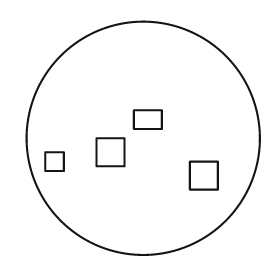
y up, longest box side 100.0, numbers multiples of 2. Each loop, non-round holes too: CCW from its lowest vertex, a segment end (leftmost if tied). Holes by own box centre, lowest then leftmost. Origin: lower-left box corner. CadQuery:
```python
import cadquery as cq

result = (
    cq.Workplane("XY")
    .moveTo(50.0, 50.0)
    .circle(50.0)
    .moveTo(70.0, 28.0)
    .lineTo(82.0, 28.0)
    .lineTo(82.0, 40.0)
    .lineTo(70.0, 40.0)
    .close()
    .moveTo(8.0, 36.0)
    .lineTo(16.0, 36.0)
    .lineTo(16.0, 44.0)
    .lineTo(8.0, 44.0)
    .close()
    .moveTo(30.0, 38.0)
    .lineTo(42.0, 38.0)
    .lineTo(42.0, 50.0)
    .lineTo(30.0, 50.0)
    .close()
    .moveTo(46.0, 54.0)
    .lineTo(58.0, 54.0)
    .lineTo(58.0, 62.0)
    .lineTo(46.0, 62.0)
    .close()
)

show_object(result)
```